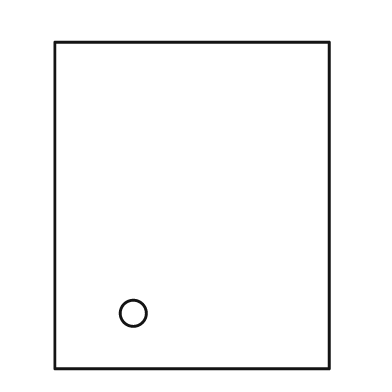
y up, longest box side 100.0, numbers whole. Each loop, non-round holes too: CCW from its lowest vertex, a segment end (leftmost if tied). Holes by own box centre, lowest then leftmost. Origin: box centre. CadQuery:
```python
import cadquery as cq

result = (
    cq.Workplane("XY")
    .moveTo(-42.0, -50.0)
    .lineTo(42.0, -50.0)
    .lineTo(42.0, 50.0)
    .lineTo(-42.0, 50.0)
    .close()
    .moveTo(-18.0, -33.0)
    .circle(4.0)
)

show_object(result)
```